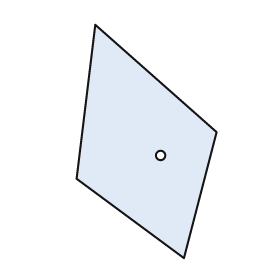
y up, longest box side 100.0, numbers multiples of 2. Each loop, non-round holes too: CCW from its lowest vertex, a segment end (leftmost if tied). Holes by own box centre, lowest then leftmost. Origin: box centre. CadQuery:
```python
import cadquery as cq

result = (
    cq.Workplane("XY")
    .moveTo(16.0, -50.0)
    .lineTo(30.0, 4.0)
    .lineTo(-22.0, 50.0)
    .lineTo(-30.0, -16.0)
    .close()
    .moveTo(6.0, -6.0)
    .circle(2.0)
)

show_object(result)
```